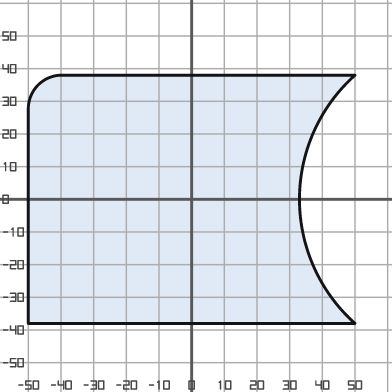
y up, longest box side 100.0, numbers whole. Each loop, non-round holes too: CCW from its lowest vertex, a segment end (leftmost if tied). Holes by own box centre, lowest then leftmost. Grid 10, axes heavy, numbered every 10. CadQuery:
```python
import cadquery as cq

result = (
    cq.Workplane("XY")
    .moveTo(-50.0, -38.0)
    .lineTo(50.0, -38.0)
    .threePointArc((33.0, 0.0), (50.0, 38.0))
    .lineTo(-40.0, 38.0)
    .threePointArc((-47.0, 35.0), (-50.0, 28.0))
    .close()
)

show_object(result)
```